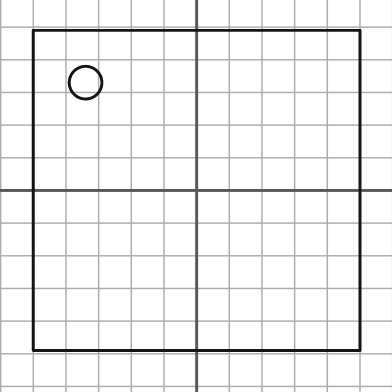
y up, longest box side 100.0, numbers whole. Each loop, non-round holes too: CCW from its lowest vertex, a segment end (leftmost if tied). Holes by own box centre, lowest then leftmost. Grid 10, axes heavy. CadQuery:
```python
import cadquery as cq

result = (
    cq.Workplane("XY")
    .moveTo(-50.0, -49.0)
    .lineTo(50.0, -49.0)
    .lineTo(50.0, 49.0)
    .lineTo(-50.0, 49.0)
    .close()
    .moveTo(-34.0, 33.0)
    .circle(5.0)
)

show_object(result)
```